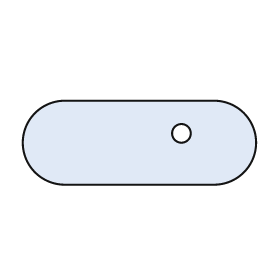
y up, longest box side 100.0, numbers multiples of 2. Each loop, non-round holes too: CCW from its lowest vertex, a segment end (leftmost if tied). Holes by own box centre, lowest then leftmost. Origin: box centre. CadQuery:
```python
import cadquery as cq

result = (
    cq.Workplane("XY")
    .moveTo(-32.0, -18.0)
    .lineTo(32.0, -18.0)
    .threePointArc((50.0, 0.0), (32.0, 18.0))
    .lineTo(-32.0, 18.0)
    .threePointArc((-50.0, 0.0), (-32.0, -18.0))
    .close()
    .moveTo(18.0, 4.0)
    .circle(4.0)
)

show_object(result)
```